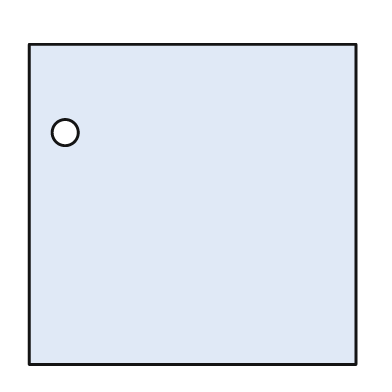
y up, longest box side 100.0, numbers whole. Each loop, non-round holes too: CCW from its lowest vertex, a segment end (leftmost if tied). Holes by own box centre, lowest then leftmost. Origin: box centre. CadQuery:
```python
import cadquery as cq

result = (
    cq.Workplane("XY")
    .moveTo(-50.0, -49.0)
    .lineTo(50.0, -49.0)
    .lineTo(50.0, 49.0)
    .lineTo(-50.0, 49.0)
    .close()
    .moveTo(-39.0, 22.0)
    .circle(4.0)
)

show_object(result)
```